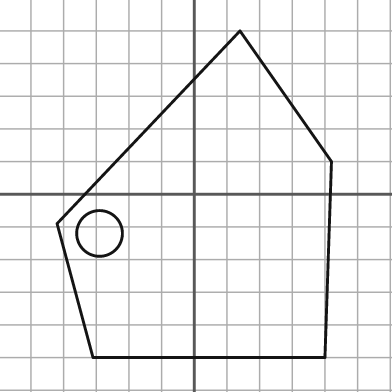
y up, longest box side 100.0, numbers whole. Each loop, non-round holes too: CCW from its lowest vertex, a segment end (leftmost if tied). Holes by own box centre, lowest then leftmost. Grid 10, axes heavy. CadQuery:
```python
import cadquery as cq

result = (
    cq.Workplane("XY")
    .moveTo(-31.0, -50.0)
    .lineTo(40.0, -50.0)
    .lineTo(42.0, 10.0)
    .lineTo(14.0, 50.0)
    .lineTo(-42.0, -9.0)
    .close()
    .moveTo(-29.0, -12.0)
    .circle(7.0)
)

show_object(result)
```